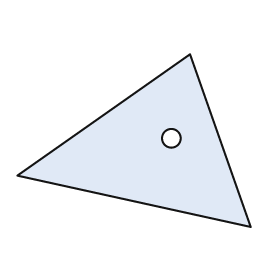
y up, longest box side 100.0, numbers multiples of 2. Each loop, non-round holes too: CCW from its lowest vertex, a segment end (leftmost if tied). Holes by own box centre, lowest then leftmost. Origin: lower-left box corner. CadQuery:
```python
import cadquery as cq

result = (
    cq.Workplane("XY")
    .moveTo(100.0, 0.0)
    .lineTo(74.0, 74.0)
    .lineTo(0.0, 22.0)
    .close()
    .moveTo(66.0, 38.0)
    .circle(4.0)
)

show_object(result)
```